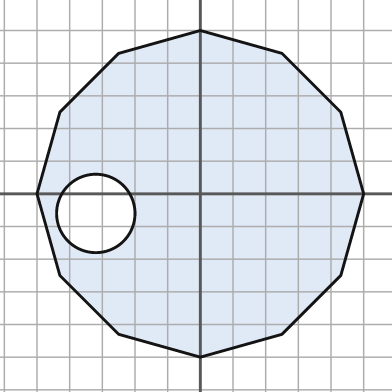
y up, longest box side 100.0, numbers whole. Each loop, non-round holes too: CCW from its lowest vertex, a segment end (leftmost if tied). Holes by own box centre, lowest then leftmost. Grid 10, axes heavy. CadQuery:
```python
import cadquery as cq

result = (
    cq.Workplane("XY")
    .moveTo(0.0, -50.0)
    .lineTo(25.0, -43.0)
    .lineTo(43.0, -25.0)
    .lineTo(50.0, 0.0)
    .lineTo(43.0, 25.0)
    .lineTo(25.0, 43.0)
    .lineTo(0.0, 50.0)
    .lineTo(-25.0, 43.0)
    .lineTo(-43.0, 25.0)
    .lineTo(-50.0, 0.0)
    .lineTo(-43.0, -25.0)
    .lineTo(-25.0, -43.0)
    .close()
    .moveTo(-32.0, -6.0)
    .circle(12.0)
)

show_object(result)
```